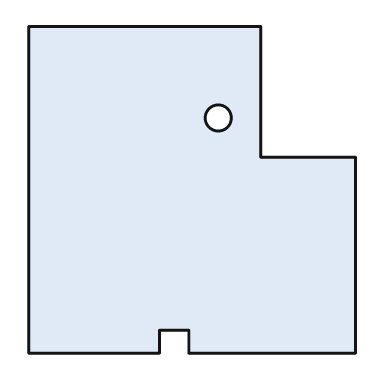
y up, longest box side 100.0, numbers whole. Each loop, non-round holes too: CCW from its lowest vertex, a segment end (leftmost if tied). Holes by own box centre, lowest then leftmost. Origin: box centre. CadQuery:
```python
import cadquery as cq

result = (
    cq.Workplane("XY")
    .moveTo(-50.0, -50.0)
    .lineTo(-10.0, -50.0)
    .lineTo(-10.0, -43.0)
    .lineTo(-1.0, -43.0)
    .lineTo(-1.0, -50.0)
    .lineTo(50.0, -50.0)
    .lineTo(50.0, 10.0)
    .lineTo(21.0, 10.0)
    .lineTo(21.0, 50.0)
    .lineTo(-50.0, 50.0)
    .close()
    .moveTo(8.0, 22.0)
    .circle(4.0)
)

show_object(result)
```